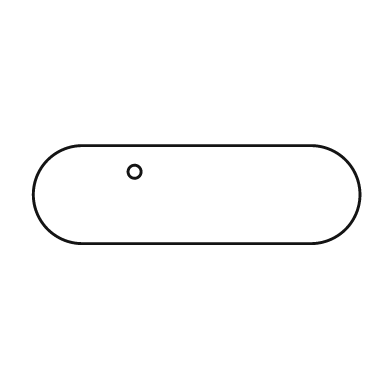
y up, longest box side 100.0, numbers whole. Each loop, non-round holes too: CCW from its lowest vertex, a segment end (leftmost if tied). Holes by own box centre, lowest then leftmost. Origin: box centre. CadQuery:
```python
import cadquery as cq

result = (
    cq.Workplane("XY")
    .moveTo(-35.0, -15.0)
    .lineTo(35.0, -15.0)
    .threePointArc((50.0, 0.0), (35.0, 15.0))
    .lineTo(-35.0, 15.0)
    .threePointArc((-50.0, 0.0), (-35.0, -15.0))
    .close()
    .moveTo(-19.0, 7.0)
    .circle(2.0)
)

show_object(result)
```